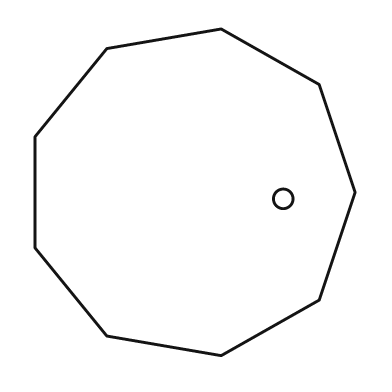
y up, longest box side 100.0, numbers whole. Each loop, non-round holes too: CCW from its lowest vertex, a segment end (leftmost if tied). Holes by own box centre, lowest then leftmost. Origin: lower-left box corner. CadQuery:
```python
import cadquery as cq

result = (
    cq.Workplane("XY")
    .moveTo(57.0, 0.0)
    .lineTo(87.0, 17.0)
    .lineTo(98.0, 50.0)
    .lineTo(87.0, 83.0)
    .lineTo(57.0, 100.0)
    .lineTo(22.0, 94.0)
    .lineTo(0.0, 67.0)
    .lineTo(0.0, 33.0)
    .lineTo(22.0, 6.0)
    .close()
    .moveTo(76.0, 48.0)
    .circle(3.0)
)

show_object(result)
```